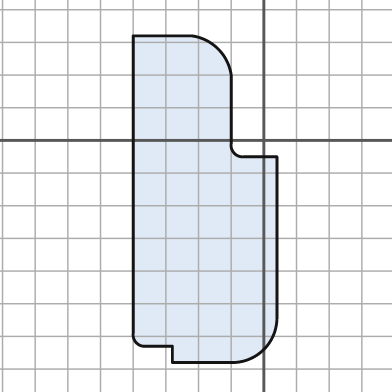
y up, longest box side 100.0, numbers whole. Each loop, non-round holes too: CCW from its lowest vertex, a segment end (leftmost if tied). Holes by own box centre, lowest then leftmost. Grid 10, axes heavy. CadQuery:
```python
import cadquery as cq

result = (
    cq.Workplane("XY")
    .moveTo(-28.0, -68.0)
    .lineTo(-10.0, -68.0)
    .threePointArc((0.0, -64.0), (4.0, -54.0))
    .lineTo(4.0, -5.0)
    .lineTo(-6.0, -5.0)
    .threePointArc((-9.0, -4.0), (-10.0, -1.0))
    .lineTo(-10.0, 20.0)
    .threePointArc((-14.0, 28.0), (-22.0, 32.0))
    .lineTo(-40.0, 32.0)
    .lineTo(-40.0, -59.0)
    .threePointArc((-39.0, -62.0), (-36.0, -63.0))
    .lineTo(-28.0, -63.0)
    .close()
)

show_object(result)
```